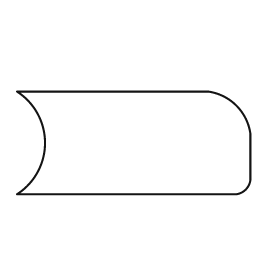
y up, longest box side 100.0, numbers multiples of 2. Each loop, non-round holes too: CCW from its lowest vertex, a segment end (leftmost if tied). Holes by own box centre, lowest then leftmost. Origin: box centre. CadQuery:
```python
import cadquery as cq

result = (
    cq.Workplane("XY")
    .moveTo(-50.0, -22.0)
    .lineTo(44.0, -22.0)
    .threePointArc((48.0, -20.0), (50.0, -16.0))
    .lineTo(50.0, 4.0)
    .threePointArc((44.0, 16.0), (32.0, 22.0))
    .lineTo(-50.0, 22.0)
    .threePointArc((-38.0, 0.0), (-50.0, -22.0))
    .close()
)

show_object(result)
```